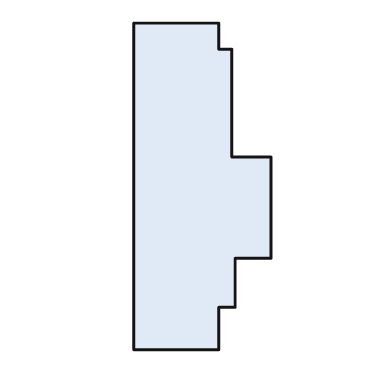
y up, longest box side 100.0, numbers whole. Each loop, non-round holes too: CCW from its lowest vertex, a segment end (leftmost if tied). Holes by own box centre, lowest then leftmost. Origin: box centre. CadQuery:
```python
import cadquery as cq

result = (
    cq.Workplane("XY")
    .moveTo(-21.0, -50.0)
    .lineTo(5.0, -50.0)
    .lineTo(5.0, -37.0)
    .lineTo(10.0, -37.0)
    .lineTo(10.0, -22.0)
    .lineTo(21.0, -22.0)
    .lineTo(21.0, 9.0)
    .lineTo(9.0, 9.0)
    .lineTo(9.0, 42.0)
    .lineTo(5.0, 42.0)
    .lineTo(5.0, 50.0)
    .lineTo(-21.0, 50.0)
    .close()
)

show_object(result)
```